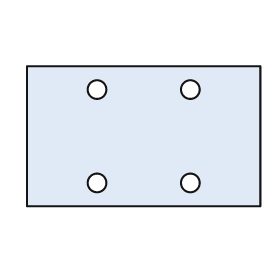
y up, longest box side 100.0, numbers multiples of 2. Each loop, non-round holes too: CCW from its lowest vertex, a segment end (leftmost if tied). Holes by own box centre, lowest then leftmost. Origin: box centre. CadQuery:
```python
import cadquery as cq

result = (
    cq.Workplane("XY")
    .moveTo(-50.0, -30.0)
    .lineTo(50.0, -30.0)
    .lineTo(50.0, 30.0)
    .lineTo(-50.0, 30.0)
    .close()
    .moveTo(-20.0, -20.0)
    .circle(4.0)
    .moveTo(20.0, -20.0)
    .circle(4.0)
    .moveTo(-20.0, 20.0)
    .circle(4.0)
    .moveTo(20.0, 20.0)
    .circle(4.0)
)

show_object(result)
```